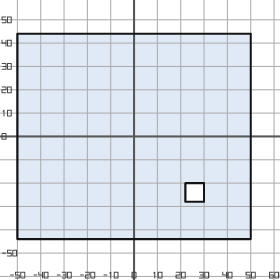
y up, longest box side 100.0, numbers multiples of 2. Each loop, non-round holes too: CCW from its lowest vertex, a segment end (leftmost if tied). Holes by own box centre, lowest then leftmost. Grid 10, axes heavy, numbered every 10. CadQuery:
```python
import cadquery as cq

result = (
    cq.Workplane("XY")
    .moveTo(-50.0, -44.0)
    .lineTo(50.0, -44.0)
    .lineTo(50.0, 44.0)
    .lineTo(-50.0, 44.0)
    .close()
    .moveTo(22.0, -28.0)
    .lineTo(30.0, -28.0)
    .lineTo(30.0, -20.0)
    .lineTo(22.0, -20.0)
    .close()
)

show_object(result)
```